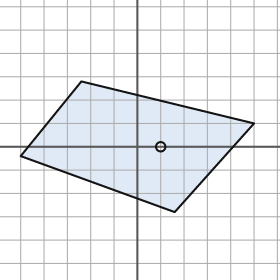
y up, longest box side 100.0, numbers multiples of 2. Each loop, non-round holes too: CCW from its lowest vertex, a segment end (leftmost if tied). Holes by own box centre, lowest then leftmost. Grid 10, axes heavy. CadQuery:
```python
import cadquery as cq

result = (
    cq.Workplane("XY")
    .moveTo(16.0, -28.0)
    .lineTo(50.0, 10.0)
    .lineTo(-24.0, 28.0)
    .lineTo(-50.0, -4.0)
    .close()
    .moveTo(10.0, 0.0)
    .circle(2.0)
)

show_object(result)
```